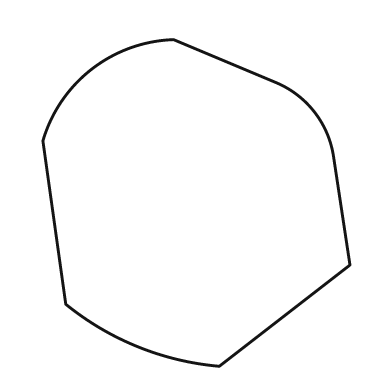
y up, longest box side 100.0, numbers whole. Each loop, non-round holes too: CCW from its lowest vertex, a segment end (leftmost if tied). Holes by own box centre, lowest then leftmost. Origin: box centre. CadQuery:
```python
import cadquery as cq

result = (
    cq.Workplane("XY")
    .moveTo(7.0, -50.0)
    .lineTo(47.0, -19.0)
    .lineTo(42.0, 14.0)
    .threePointArc((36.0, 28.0), (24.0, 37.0))
    .lineTo(-7.0, 50.0)
    .threePointArc((-32.0, 41.0), (-47.0, 19.0))
    .lineTo(-40.0, -31.0)
    .threePointArc((-18.0, -44.0), (7.0, -50.0))
    .close()
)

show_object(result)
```